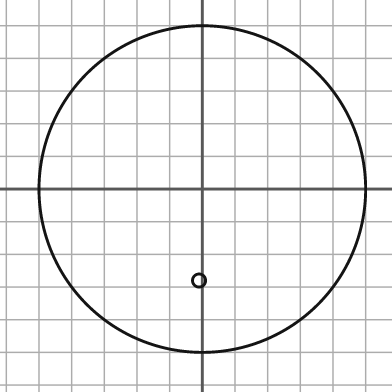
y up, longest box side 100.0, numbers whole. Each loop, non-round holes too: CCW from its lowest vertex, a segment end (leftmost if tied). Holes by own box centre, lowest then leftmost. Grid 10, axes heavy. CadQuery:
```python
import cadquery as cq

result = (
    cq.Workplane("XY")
    .moveTo(0.0, 0.0)
    .circle(50.0)
    .moveTo(-1.0, -28.0)
    .circle(2.0)
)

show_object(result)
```